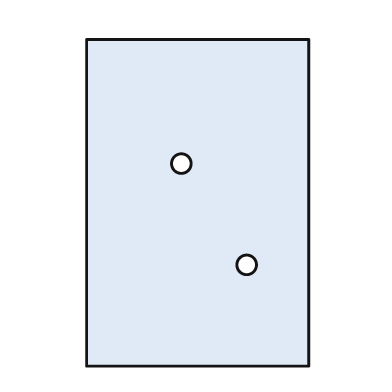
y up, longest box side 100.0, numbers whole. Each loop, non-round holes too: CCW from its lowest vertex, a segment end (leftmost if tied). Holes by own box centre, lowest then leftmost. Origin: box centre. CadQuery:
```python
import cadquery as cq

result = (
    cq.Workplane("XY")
    .moveTo(-34.0, -50.0)
    .lineTo(34.0, -50.0)
    .lineTo(34.0, 50.0)
    .lineTo(-34.0, 50.0)
    .close()
    .moveTo(15.0, -19.0)
    .circle(3.0)
    .moveTo(-5.0, 12.0)
    .circle(3.0)
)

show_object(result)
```